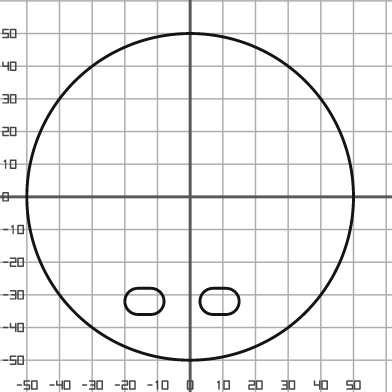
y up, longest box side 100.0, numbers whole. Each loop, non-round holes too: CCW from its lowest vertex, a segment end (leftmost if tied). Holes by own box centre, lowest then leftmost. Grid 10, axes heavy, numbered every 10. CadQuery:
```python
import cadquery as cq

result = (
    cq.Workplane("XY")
    .moveTo(0.0, 0.0)
    .circle(50.0)
    .moveTo(-16.0, -36.0)
    .lineTo(-12.0, -36.0)
    .threePointArc((-8.0, -32.0), (-12.0, -28.0))
    .lineTo(-16.0, -28.0)
    .threePointArc((-20.0, -32.0), (-16.0, -36.0))
    .close()
    .moveTo(7.0, -36.0)
    .lineTo(11.0, -36.0)
    .threePointArc((15.0, -32.0), (11.0, -28.0))
    .lineTo(7.0, -28.0)
    .threePointArc((3.0, -32.0), (7.0, -36.0))
    .close()
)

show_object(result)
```